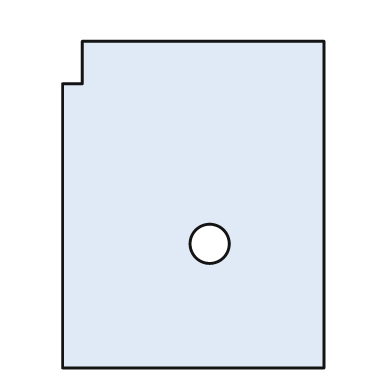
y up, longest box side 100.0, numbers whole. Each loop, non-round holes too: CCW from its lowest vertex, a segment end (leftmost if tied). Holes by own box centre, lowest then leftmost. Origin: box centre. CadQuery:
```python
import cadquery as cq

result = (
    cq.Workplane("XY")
    .moveTo(-40.0, -50.0)
    .lineTo(40.0, -50.0)
    .lineTo(40.0, 50.0)
    .lineTo(-34.0, 50.0)
    .lineTo(-34.0, 37.0)
    .lineTo(-40.0, 37.0)
    .close()
    .moveTo(5.0, -12.0)
    .circle(6.0)
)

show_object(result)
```